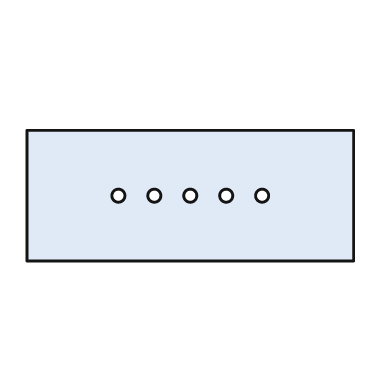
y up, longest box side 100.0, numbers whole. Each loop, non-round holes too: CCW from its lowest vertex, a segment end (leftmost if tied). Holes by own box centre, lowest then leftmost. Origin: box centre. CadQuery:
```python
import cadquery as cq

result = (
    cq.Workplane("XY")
    .moveTo(-50.0, -20.0)
    .lineTo(50.0, -20.0)
    .lineTo(50.0, 20.0)
    .lineTo(-50.0, 20.0)
    .close()
    .moveTo(-22.0, 0.0)
    .circle(2.0)
    .moveTo(-11.0, 0.0)
    .circle(2.0)
    .moveTo(0.0, 0.0)
    .circle(2.0)
    .moveTo(11.0, 0.0)
    .circle(2.0)
    .moveTo(22.0, 0.0)
    .circle(2.0)
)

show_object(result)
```